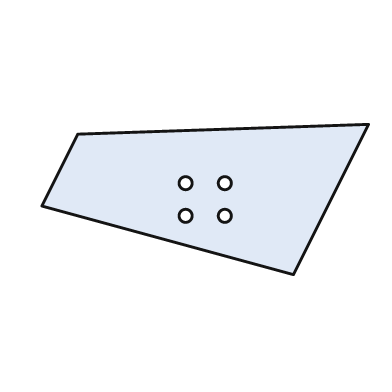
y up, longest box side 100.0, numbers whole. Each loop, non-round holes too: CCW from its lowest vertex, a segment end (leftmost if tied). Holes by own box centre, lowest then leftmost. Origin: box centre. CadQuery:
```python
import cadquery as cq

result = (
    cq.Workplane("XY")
    .moveTo(27.0, -23.0)
    .lineTo(50.0, 23.0)
    .lineTo(-39.0, 20.0)
    .lineTo(-50.0, -2.0)
    .close()
    .moveTo(-6.0, -5.0)
    .circle(2.0)
    .moveTo(6.0, -5.0)
    .circle(2.0)
    .moveTo(-6.0, 5.0)
    .circle(2.0)
    .moveTo(6.0, 5.0)
    .circle(2.0)
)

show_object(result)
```